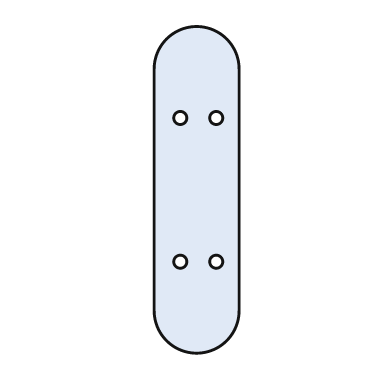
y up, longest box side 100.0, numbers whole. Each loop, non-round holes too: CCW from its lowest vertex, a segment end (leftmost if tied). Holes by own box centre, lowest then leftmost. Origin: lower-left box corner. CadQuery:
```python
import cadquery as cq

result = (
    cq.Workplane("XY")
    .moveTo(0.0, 13.0)
    .threePointArc((13.0, 0.0), (26.0, 13.0))
    .lineTo(26.0, 87.0)
    .threePointArc((13.0, 100.0), (0.0, 87.0))
    .close()
    .moveTo(8.0, 28.0)
    .circle(2.0)
    .moveTo(19.0, 28.0)
    .circle(2.0)
    .moveTo(8.0, 72.0)
    .circle(2.0)
    .moveTo(19.0, 72.0)
    .circle(2.0)
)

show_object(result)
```